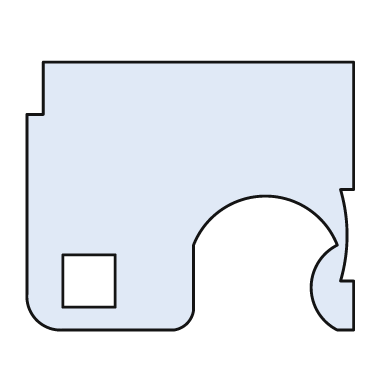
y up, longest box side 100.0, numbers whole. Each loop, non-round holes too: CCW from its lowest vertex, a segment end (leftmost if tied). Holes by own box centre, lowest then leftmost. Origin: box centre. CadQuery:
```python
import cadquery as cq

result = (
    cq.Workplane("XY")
    .moveTo(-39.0, -41.0)
    .lineTo(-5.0, -41.0)
    .threePointArc((-1.0, -39.0), (1.0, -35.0))
    .lineTo(1.0, -15.0)
    .threePointArc((23.0, 0.0), (45.0, -15.0))
    .threePointArc((37.0, -28.0), (45.0, -41.0))
    .lineTo(50.0, -41.0)
    .lineTo(50.0, -26.0)
    .lineTo(46.0, -26.0)
    .threePointArc((48.0, -12.0), (46.0, 2.0))
    .lineTo(50.0, 2.0)
    .lineTo(50.0, 41.0)
    .lineTo(-45.0, 41.0)
    .lineTo(-45.0, 25.0)
    .lineTo(-50.0, 25.0)
    .lineTo(-50.0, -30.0)
    .threePointArc((-47.0, -38.0), (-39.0, -41.0))
    .close()
    .moveTo(-39.0, -34.0)
    .lineTo(-23.0, -34.0)
    .lineTo(-23.0, -18.0)
    .lineTo(-39.0, -18.0)
    .close()
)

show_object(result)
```